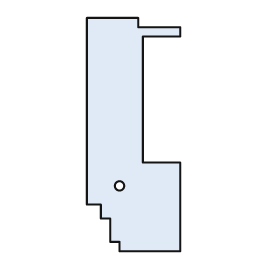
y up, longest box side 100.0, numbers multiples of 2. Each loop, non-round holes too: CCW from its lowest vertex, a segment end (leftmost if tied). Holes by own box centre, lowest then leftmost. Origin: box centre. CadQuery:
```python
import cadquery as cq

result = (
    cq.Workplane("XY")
    .moveTo(-6.0, -50.0)
    .lineTo(20.0, -50.0)
    .lineTo(20.0, -12.0)
    .lineTo(4.0, -12.0)
    .lineTo(4.0, 42.0)
    .lineTo(20.0, 42.0)
    .lineTo(20.0, 46.0)
    .lineTo(2.0, 46.0)
    .lineTo(2.0, 50.0)
    .lineTo(-20.0, 50.0)
    .lineTo(-20.0, -30.0)
    .lineTo(-14.0, -30.0)
    .lineTo(-14.0, -36.0)
    .lineTo(-10.0, -36.0)
    .lineTo(-10.0, -46.0)
    .lineTo(-6.0, -46.0)
    .close()
    .moveTo(-6.0, -22.0)
    .circle(2.0)
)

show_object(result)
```